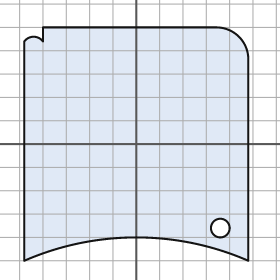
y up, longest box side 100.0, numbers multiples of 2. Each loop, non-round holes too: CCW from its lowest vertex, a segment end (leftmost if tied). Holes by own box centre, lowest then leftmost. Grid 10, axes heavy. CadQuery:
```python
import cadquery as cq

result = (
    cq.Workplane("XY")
    .moveTo(-48.0, -50.0)
    .threePointArc((0.0, -40.0), (48.0, -50.0))
    .lineTo(48.0, 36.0)
    .threePointArc((44.0, 46.0), (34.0, 50.0))
    .lineTo(-40.0, 50.0)
    .lineTo(-40.0, 44.0)
    .threePointArc((-44.0, 46.0), (-48.0, 44.0))
    .close()
    .moveTo(36.0, -36.0)
    .circle(4.0)
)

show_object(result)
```